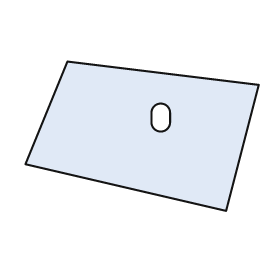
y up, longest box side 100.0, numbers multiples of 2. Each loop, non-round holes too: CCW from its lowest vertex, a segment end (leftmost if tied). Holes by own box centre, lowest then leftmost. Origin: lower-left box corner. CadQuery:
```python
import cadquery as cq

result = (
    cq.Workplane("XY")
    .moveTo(86.0, 0.0)
    .lineTo(100.0, 54.0)
    .lineTo(18.0, 64.0)
    .lineTo(0.0, 20.0)
    .close()
    .moveTo(54.0, 38.0)
    .threePointArc((58.0, 34.0), (62.0, 38.0))
    .lineTo(62.0, 42.0)
    .threePointArc((58.0, 46.0), (54.0, 42.0))
    .close()
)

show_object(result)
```